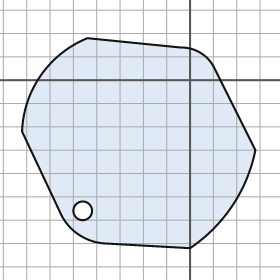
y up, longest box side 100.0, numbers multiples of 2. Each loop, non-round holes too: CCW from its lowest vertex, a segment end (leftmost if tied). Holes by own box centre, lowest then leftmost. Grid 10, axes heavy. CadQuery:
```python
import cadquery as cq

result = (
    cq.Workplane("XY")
    .moveTo(0.0, -72.0)
    .threePointArc((18.0, -54.0), (28.0, -30.0))
    .lineTo(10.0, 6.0)
    .threePointArc((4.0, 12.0), (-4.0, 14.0))
    .lineTo(-44.0, 18.0)
    .threePointArc((-64.0, 2.0), (-72.0, -22.0))
    .lineTo(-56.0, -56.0)
    .threePointArc((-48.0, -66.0), (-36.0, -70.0))
    .close()
    .moveTo(-46.0, -56.0)
    .circle(4.0)
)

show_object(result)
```